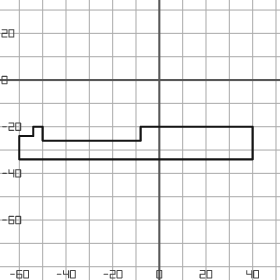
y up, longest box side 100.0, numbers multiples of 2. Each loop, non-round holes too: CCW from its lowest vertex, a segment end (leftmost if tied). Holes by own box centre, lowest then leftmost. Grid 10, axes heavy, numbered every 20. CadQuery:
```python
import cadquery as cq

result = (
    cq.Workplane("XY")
    .moveTo(-60.0, -34.0)
    .lineTo(40.0, -34.0)
    .lineTo(40.0, -20.0)
    .lineTo(-8.0, -20.0)
    .lineTo(-8.0, -26.0)
    .lineTo(-50.0, -26.0)
    .lineTo(-50.0, -20.0)
    .lineTo(-54.0, -20.0)
    .lineTo(-54.0, -24.0)
    .lineTo(-60.0, -24.0)
    .close()
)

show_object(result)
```